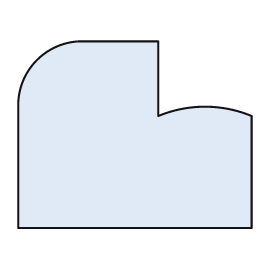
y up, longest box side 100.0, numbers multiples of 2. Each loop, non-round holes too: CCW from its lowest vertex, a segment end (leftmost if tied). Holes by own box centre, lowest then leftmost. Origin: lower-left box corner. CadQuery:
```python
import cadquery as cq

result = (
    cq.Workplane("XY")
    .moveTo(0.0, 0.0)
    .lineTo(100.0, 0.0)
    .lineTo(100.0, 48.0)
    .threePointArc((80.0, 52.0), (60.0, 48.0))
    .lineTo(60.0, 80.0)
    .lineTo(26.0, 80.0)
    .threePointArc((8.0, 72.0), (0.0, 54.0))
    .close()
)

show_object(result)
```